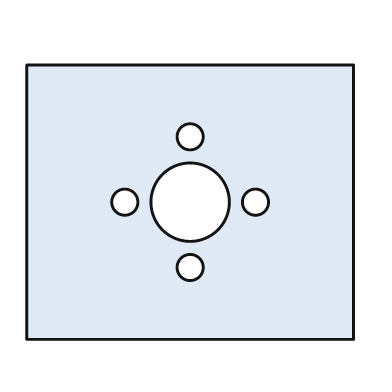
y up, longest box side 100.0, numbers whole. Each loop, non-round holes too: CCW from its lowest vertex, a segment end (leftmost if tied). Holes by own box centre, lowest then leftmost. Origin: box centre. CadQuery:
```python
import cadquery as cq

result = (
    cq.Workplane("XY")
    .moveTo(-50.0, -42.0)
    .lineTo(50.0, -42.0)
    .lineTo(50.0, 42.0)
    .lineTo(-50.0, 42.0)
    .close()
    .moveTo(0.0, -20.0)
    .circle(4.0)
    .moveTo(-20.0, 0.0)
    .circle(4.0)
    .moveTo(0.0, 0.0)
    .circle(12.0)
    .moveTo(20.0, 0.0)
    .circle(4.0)
    .moveTo(0.0, 20.0)
    .circle(4.0)
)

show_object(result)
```